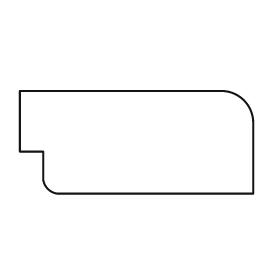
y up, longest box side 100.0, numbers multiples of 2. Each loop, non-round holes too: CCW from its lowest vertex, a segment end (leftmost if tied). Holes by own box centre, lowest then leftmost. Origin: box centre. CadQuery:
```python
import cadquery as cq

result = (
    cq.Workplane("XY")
    .moveTo(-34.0, -22.0)
    .lineTo(50.0, -22.0)
    .lineTo(50.0, 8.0)
    .threePointArc((46.0, 18.0), (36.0, 22.0))
    .lineTo(-50.0, 22.0)
    .lineTo(-50.0, -4.0)
    .lineTo(-40.0, -4.0)
    .lineTo(-40.0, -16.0)
    .threePointArc((-38.0, -20.0), (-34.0, -22.0))
    .close()
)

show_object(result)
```